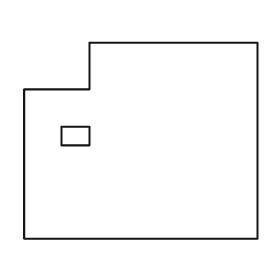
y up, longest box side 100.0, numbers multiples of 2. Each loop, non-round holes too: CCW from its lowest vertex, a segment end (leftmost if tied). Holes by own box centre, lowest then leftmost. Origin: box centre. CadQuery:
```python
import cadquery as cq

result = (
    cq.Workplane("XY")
    .moveTo(-50.0, -42.0)
    .lineTo(50.0, -42.0)
    .lineTo(50.0, 42.0)
    .lineTo(-22.0, 42.0)
    .lineTo(-22.0, 22.0)
    .lineTo(-50.0, 22.0)
    .close()
    .moveTo(-34.0, -2.0)
    .lineTo(-22.0, -2.0)
    .lineTo(-22.0, 6.0)
    .lineTo(-34.0, 6.0)
    .close()
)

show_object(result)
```